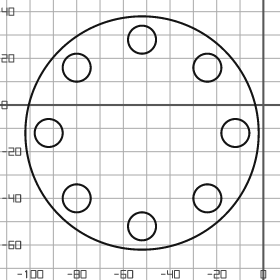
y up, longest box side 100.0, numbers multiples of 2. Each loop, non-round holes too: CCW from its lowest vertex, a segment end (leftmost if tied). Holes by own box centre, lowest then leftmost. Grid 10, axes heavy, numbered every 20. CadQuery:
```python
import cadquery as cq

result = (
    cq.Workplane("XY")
    .moveTo(-52.0, -12.0)
    .circle(50.0)
    .moveTo(-52.0, -52.0)
    .circle(6.0)
    .moveTo(-80.0, -40.0)
    .circle(6.0)
    .moveTo(-24.0, -40.0)
    .circle(6.0)
    .moveTo(-92.0, -12.0)
    .circle(6.0)
    .moveTo(-12.0, -12.0)
    .circle(6.0)
    .moveTo(-80.0, 16.0)
    .circle(6.0)
    .moveTo(-24.0, 16.0)
    .circle(6.0)
    .moveTo(-52.0, 28.0)
    .circle(6.0)
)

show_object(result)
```